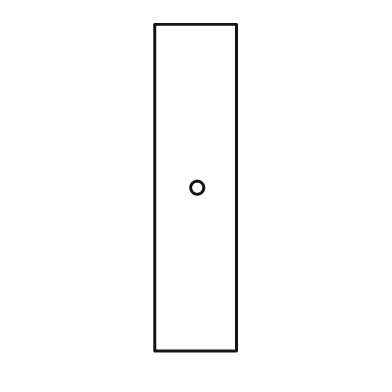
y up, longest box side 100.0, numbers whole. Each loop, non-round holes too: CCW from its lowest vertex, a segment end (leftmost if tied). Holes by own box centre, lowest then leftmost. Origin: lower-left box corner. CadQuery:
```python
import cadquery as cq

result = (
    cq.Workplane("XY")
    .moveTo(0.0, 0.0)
    .lineTo(25.0, 0.0)
    .lineTo(25.0, 100.0)
    .lineTo(0.0, 100.0)
    .close()
    .moveTo(13.0, 50.0)
    .circle(2.0)
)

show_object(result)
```